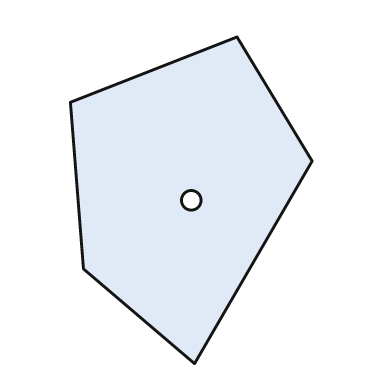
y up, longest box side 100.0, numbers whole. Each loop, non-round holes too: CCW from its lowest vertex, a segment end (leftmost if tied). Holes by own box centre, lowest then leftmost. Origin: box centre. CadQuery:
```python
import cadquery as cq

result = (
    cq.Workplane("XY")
    .moveTo(1.0, -50.0)
    .lineTo(37.0, 12.0)
    .lineTo(14.0, 50.0)
    .lineTo(-37.0, 30.0)
    .lineTo(-33.0, -21.0)
    .close()
    .moveTo(0.0, 0.0)
    .circle(3.0)
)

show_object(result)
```